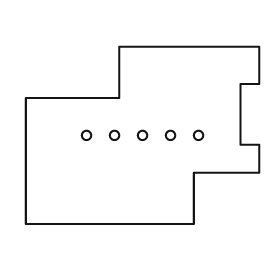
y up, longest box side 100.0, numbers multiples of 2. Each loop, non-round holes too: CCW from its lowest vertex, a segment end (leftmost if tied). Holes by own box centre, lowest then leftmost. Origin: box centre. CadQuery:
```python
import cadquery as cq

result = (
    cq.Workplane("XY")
    .moveTo(-50.0, -38.0)
    .lineTo(22.0, -38.0)
    .lineTo(22.0, -16.0)
    .lineTo(50.0, -16.0)
    .lineTo(50.0, -4.0)
    .lineTo(42.0, -4.0)
    .lineTo(42.0, 22.0)
    .lineTo(50.0, 22.0)
    .lineTo(50.0, 38.0)
    .lineTo(-10.0, 38.0)
    .lineTo(-10.0, 16.0)
    .lineTo(-50.0, 16.0)
    .close()
    .moveTo(-24.0, 0.0)
    .circle(2.0)
    .moveTo(-12.0, 0.0)
    .circle(2.0)
    .moveTo(0.0, 0.0)
    .circle(2.0)
    .moveTo(12.0, 0.0)
    .circle(2.0)
    .moveTo(24.0, 0.0)
    .circle(2.0)
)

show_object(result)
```